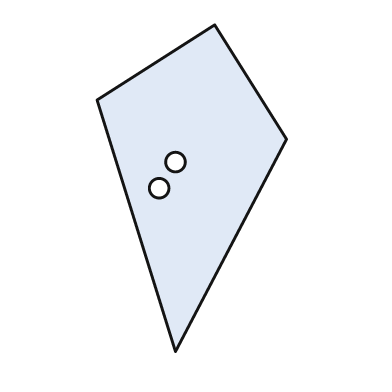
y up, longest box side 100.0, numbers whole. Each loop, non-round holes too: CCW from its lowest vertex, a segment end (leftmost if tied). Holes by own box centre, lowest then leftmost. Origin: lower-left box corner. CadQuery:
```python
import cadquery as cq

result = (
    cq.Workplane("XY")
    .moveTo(24.0, 0.0)
    .lineTo(58.0, 65.0)
    .lineTo(36.0, 100.0)
    .lineTo(0.0, 77.0)
    .close()
    .moveTo(19.0, 50.0)
    .circle(3.0)
    .moveTo(24.0, 58.0)
    .circle(3.0)
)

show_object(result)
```